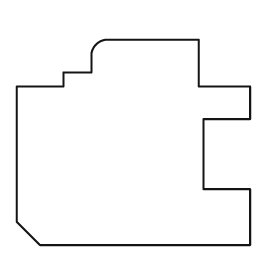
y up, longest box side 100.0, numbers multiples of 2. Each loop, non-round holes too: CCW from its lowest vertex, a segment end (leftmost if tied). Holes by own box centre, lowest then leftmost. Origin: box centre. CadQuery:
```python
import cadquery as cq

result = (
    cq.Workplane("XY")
    .moveTo(-40.0, -44.0)
    .lineTo(50.0, -44.0)
    .lineTo(50.0, -20.0)
    .lineTo(30.0, -20.0)
    .lineTo(30.0, 10.0)
    .lineTo(50.0, 10.0)
    .lineTo(50.0, 24.0)
    .lineTo(28.0, 24.0)
    .lineTo(28.0, 44.0)
    .lineTo(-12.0, 44.0)
    .threePointArc((-16.0, 42.0), (-18.0, 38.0))
    .lineTo(-18.0, 30.0)
    .lineTo(-30.0, 30.0)
    .lineTo(-30.0, 24.0)
    .lineTo(-50.0, 24.0)
    .lineTo(-50.0, -34.0)
    .close()
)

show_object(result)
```